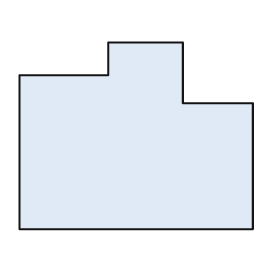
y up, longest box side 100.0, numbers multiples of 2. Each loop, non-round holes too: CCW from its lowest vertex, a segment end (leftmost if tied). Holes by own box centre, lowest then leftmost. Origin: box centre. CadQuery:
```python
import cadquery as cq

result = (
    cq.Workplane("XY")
    .moveTo(-50.0, -40.0)
    .lineTo(50.0, -40.0)
    .lineTo(50.0, 14.0)
    .lineTo(20.0, 14.0)
    .lineTo(20.0, 40.0)
    .lineTo(-12.0, 40.0)
    .lineTo(-12.0, 26.0)
    .lineTo(-50.0, 26.0)
    .close()
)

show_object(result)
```